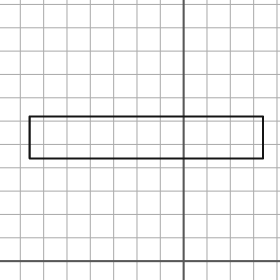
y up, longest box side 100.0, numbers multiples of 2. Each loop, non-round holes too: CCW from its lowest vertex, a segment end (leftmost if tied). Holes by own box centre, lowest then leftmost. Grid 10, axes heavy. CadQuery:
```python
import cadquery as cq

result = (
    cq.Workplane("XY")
    .moveTo(-66.0, 44.0)
    .lineTo(34.0, 44.0)
    .lineTo(34.0, 62.0)
    .lineTo(-66.0, 62.0)
    .close()
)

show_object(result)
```